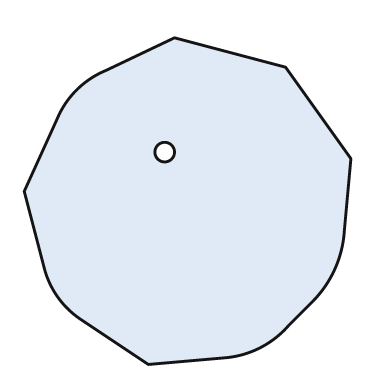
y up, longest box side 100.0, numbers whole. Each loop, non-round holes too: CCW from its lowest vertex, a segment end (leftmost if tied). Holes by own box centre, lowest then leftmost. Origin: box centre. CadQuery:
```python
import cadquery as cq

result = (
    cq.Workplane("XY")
    .moveTo(-12.0, -50.0)
    .lineTo(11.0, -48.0)
    .threePointArc((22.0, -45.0), (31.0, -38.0))
    .lineTo(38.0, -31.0)
    .threePointArc((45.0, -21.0), (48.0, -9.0))
    .lineTo(50.0, 13.0)
    .lineTo(30.0, 41.0)
    .lineTo(-4.0, 50.0)
    .lineTo(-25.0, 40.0)
    .threePointArc((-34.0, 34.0), (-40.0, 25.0))
    .lineTo(-50.0, 3.0)
    .lineTo(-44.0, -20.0)
    .threePointArc((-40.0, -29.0), (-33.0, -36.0))
    .close()
    .moveTo(-7.0, 15.0)
    .circle(3.0)
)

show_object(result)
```